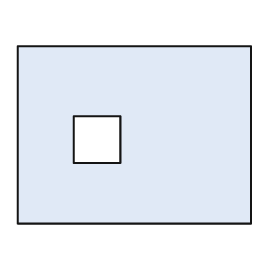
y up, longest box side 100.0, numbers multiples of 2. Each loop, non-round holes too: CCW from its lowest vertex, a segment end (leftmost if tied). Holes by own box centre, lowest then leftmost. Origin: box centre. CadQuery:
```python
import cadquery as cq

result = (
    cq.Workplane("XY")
    .moveTo(-50.0, -38.0)
    .lineTo(50.0, -38.0)
    .lineTo(50.0, 38.0)
    .lineTo(-50.0, 38.0)
    .close()
    .moveTo(-26.0, -12.0)
    .lineTo(-6.0, -12.0)
    .lineTo(-6.0, 8.0)
    .lineTo(-26.0, 8.0)
    .close()
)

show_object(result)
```